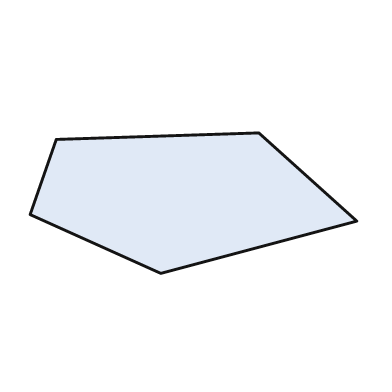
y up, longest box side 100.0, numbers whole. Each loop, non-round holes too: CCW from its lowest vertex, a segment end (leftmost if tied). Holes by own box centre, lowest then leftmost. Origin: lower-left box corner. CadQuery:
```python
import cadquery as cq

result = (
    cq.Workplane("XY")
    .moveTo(40.0, 0.0)
    .lineTo(100.0, 16.0)
    .lineTo(70.0, 43.0)
    .lineTo(8.0, 41.0)
    .lineTo(0.0, 18.0)
    .close()
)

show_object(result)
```